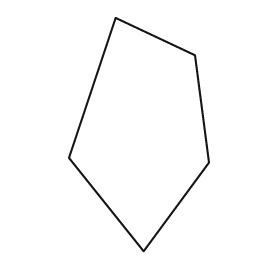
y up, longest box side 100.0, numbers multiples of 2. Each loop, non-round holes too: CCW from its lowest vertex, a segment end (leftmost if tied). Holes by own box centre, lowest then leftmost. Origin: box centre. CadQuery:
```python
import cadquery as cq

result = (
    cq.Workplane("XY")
    .moveTo(2.0, -50.0)
    .lineTo(30.0, -12.0)
    .lineTo(24.0, 34.0)
    .lineTo(-10.0, 50.0)
    .lineTo(-30.0, -10.0)
    .close()
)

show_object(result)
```